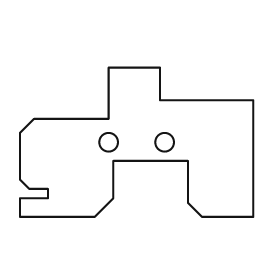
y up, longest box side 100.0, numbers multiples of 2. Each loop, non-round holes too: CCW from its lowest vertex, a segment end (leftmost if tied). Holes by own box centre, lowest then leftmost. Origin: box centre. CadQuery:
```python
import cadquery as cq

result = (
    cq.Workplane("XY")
    .moveTo(-50.0, -32.0)
    .lineTo(-18.0, -32.0)
    .lineTo(-10.0, -24.0)
    .lineTo(-10.0, -8.0)
    .lineTo(22.0, -8.0)
    .lineTo(22.0, -26.0)
    .lineTo(28.0, -32.0)
    .lineTo(50.0, -32.0)
    .lineTo(50.0, 18.0)
    .lineTo(10.0, 18.0)
    .lineTo(10.0, 32.0)
    .lineTo(-12.0, 32.0)
    .lineTo(-12.0, 10.0)
    .lineTo(-44.0, 10.0)
    .lineTo(-50.0, 4.0)
    .lineTo(-50.0, -16.0)
    .lineTo(-46.0, -20.0)
    .lineTo(-38.0, -20.0)
    .lineTo(-38.0, -24.0)
    .lineTo(-50.0, -24.0)
    .close()
    .moveTo(-12.0, 0.0)
    .circle(4.0)
    .moveTo(12.0, 0.0)
    .circle(4.0)
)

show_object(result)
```